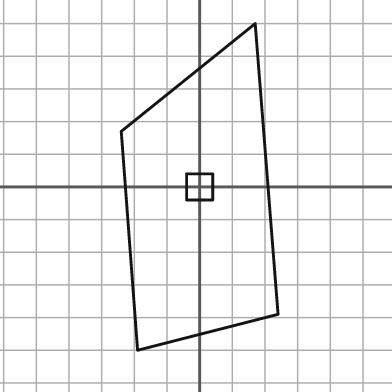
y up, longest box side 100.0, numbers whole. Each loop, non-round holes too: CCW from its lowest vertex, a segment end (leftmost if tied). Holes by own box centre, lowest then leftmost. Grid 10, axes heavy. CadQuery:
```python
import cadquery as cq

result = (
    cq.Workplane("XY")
    .moveTo(-19.0, -50.0)
    .lineTo(24.0, -39.0)
    .lineTo(17.0, 50.0)
    .lineTo(-24.0, 17.0)
    .close()
    .moveTo(-4.0, -4.0)
    .lineTo(4.0, -4.0)
    .lineTo(4.0, 4.0)
    .lineTo(-4.0, 4.0)
    .close()
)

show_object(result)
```